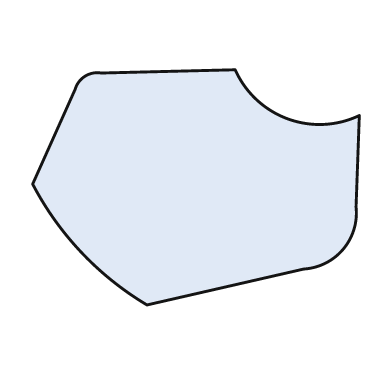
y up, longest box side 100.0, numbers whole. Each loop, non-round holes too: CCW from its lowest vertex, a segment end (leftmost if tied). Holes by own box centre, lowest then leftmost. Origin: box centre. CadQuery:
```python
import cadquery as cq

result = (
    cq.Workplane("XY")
    .moveTo(-15.0, -36.0)
    .lineTo(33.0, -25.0)
    .threePointArc((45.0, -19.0), (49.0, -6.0))
    .lineTo(50.0, 22.0)
    .threePointArc((28.0, 21.0), (12.0, 36.0))
    .lineTo(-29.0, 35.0)
    .threePointArc((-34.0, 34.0), (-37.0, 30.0))
    .lineTo(-50.0, 1.0)
    .threePointArc((-35.0, -20.0), (-15.0, -36.0))
    .close()
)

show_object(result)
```